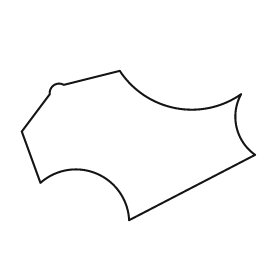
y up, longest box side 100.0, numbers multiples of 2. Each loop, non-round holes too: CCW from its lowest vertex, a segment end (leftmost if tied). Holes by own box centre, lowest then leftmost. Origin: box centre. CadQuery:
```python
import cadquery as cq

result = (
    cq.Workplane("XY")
    .moveTo(-4.0, -32.0)
    .lineTo(50.0, -4.0)
    .threePointArc((42.0, 8.0), (44.0, 22.0))
    .threePointArc((16.0, 16.0), (-8.0, 32.0))
    .lineTo(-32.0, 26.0)
    .threePointArc((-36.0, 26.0), (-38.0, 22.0))
    .lineTo(-50.0, 6.0)
    .lineTo(-42.0, -16.0)
    .threePointArc((-18.0, -12.0), (-4.0, -32.0))
    .close()
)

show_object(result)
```